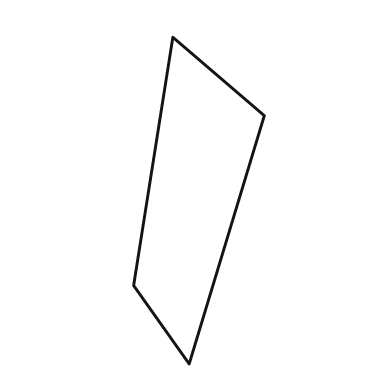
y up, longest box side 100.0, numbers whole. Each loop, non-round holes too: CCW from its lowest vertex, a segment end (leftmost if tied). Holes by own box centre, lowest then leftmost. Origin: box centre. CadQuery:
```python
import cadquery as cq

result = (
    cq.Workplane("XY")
    .moveTo(-3.0, -50.0)
    .lineTo(20.0, 26.0)
    .lineTo(-8.0, 50.0)
    .lineTo(-20.0, -26.0)
    .close()
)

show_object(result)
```